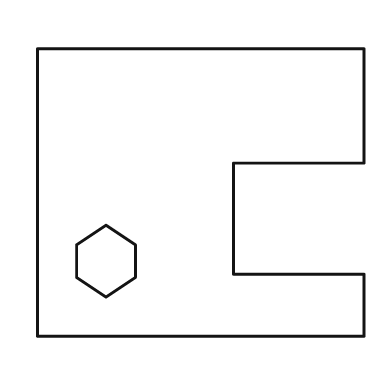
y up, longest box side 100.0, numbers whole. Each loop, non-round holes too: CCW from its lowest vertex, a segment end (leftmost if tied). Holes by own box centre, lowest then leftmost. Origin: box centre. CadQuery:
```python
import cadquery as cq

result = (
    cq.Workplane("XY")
    .moveTo(-50.0, -44.0)
    .lineTo(50.0, -44.0)
    .lineTo(50.0, -25.0)
    .lineTo(10.0, -25.0)
    .lineTo(10.0, 9.0)
    .lineTo(50.0, 9.0)
    .lineTo(50.0, 44.0)
    .lineTo(-50.0, 44.0)
    .close()
    .moveTo(-29.0, -32.0)
    .lineTo(-20.0, -26.0)
    .lineTo(-20.0, -16.0)
    .lineTo(-29.0, -10.0)
    .lineTo(-38.0, -16.0)
    .lineTo(-38.0, -26.0)
    .close()
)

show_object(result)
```